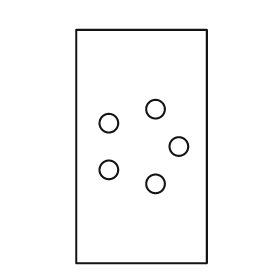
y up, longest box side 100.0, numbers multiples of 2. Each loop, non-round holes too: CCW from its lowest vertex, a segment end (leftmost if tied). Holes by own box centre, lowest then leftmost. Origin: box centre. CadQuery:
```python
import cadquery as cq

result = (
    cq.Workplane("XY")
    .moveTo(-28.0, -50.0)
    .lineTo(28.0, -50.0)
    .lineTo(28.0, 50.0)
    .lineTo(-28.0, 50.0)
    .close()
    .moveTo(6.0, -16.0)
    .circle(4.0)
    .moveTo(-14.0, -10.0)
    .circle(4.0)
    .moveTo(16.0, 0.0)
    .circle(4.0)
    .moveTo(-14.0, 10.0)
    .circle(4.0)
    .moveTo(6.0, 16.0)
    .circle(4.0)
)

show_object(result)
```